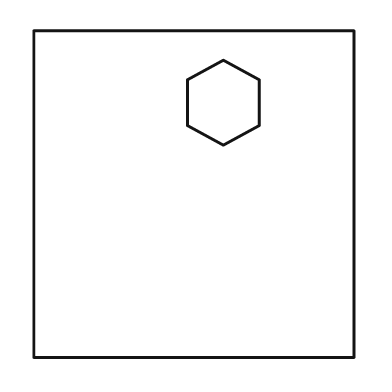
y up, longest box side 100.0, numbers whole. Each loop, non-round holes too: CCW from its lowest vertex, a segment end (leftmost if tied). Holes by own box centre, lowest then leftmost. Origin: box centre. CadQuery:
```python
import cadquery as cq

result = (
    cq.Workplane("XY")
    .moveTo(-49.0, -50.0)
    .lineTo(49.0, -50.0)
    .lineTo(49.0, 50.0)
    .lineTo(-49.0, 50.0)
    .close()
    .moveTo(9.0, 15.0)
    .lineTo(20.0, 21.0)
    .lineTo(20.0, 35.0)
    .lineTo(9.0, 41.0)
    .lineTo(-2.0, 35.0)
    .lineTo(-2.0, 21.0)
    .close()
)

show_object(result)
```